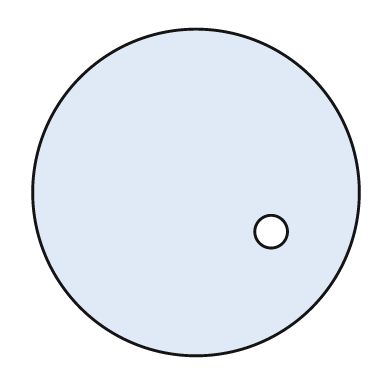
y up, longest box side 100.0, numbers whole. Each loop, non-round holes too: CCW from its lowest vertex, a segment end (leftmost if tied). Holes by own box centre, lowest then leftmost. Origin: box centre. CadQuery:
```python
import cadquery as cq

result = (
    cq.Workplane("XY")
    .moveTo(0.0, 0.0)
    .circle(50.0)
    .moveTo(23.0, -12.0)
    .circle(5.0)
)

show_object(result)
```